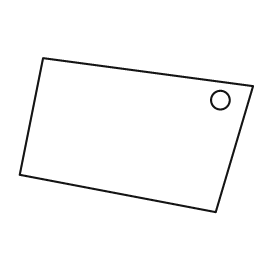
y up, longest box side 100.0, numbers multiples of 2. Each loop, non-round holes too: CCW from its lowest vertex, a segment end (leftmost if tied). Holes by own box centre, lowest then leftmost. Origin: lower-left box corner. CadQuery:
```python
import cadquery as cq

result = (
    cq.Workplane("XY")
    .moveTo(84.0, 0.0)
    .lineTo(100.0, 54.0)
    .lineTo(10.0, 66.0)
    .lineTo(0.0, 16.0)
    .close()
    .moveTo(86.0, 48.0)
    .circle(4.0)
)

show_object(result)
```